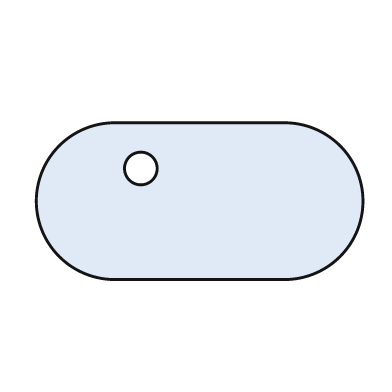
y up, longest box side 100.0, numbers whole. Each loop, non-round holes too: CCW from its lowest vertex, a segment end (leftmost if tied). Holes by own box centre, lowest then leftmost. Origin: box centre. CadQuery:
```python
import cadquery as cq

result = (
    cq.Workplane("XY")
    .moveTo(-26.0, -24.0)
    .lineTo(26.0, -24.0)
    .threePointArc((50.0, 0.0), (26.0, 24.0))
    .lineTo(-26.0, 24.0)
    .threePointArc((-50.0, 0.0), (-26.0, -24.0))
    .close()
    .moveTo(-18.0, 10.0)
    .circle(5.0)
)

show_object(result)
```